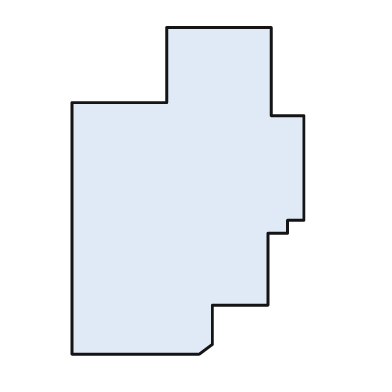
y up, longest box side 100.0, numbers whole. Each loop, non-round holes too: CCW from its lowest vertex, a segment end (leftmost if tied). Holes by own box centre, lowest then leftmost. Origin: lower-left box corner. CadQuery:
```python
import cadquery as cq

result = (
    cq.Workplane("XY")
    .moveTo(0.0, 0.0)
    .lineTo(39.0, 0.0)
    .lineTo(43.0, 3.0)
    .lineTo(43.0, 15.0)
    .lineTo(60.0, 15.0)
    .lineTo(60.0, 37.0)
    .lineTo(66.0, 37.0)
    .lineTo(66.0, 41.0)
    .lineTo(71.0, 41.0)
    .lineTo(71.0, 73.0)
    .lineTo(61.0, 73.0)
    .lineTo(61.0, 100.0)
    .lineTo(29.0, 100.0)
    .lineTo(29.0, 77.0)
    .lineTo(0.0, 77.0)
    .close()
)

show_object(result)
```